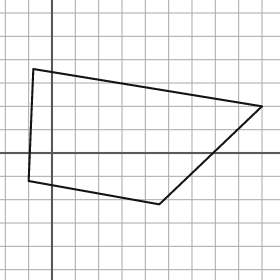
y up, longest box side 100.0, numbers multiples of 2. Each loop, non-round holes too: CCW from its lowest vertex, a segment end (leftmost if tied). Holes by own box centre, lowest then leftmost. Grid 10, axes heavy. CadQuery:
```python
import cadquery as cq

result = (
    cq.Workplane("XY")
    .moveTo(46.0, -22.0)
    .lineTo(90.0, 20.0)
    .lineTo(-8.0, 36.0)
    .lineTo(-10.0, -12.0)
    .close()
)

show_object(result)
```